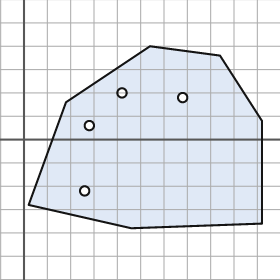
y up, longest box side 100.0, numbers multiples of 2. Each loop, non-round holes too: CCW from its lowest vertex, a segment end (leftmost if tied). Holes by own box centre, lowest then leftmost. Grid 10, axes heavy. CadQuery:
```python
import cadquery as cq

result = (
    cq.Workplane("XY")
    .moveTo(46.0, -38.0)
    .lineTo(102.0, -36.0)
    .lineTo(102.0, 8.0)
    .lineTo(84.0, 36.0)
    .lineTo(54.0, 40.0)
    .lineTo(18.0, 16.0)
    .lineTo(2.0, -28.0)
    .close()
    .moveTo(26.0, -22.0)
    .circle(2.0)
    .moveTo(28.0, 6.0)
    .circle(2.0)
    .moveTo(68.0, 18.0)
    .circle(2.0)
    .moveTo(42.0, 20.0)
    .circle(2.0)
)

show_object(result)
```